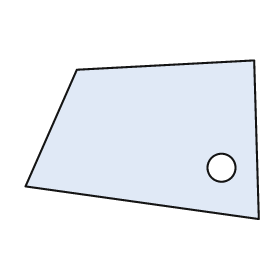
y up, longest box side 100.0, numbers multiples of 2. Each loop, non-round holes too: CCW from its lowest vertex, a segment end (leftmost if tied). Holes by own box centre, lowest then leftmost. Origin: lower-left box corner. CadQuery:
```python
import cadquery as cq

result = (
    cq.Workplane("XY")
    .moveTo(100.0, 0.0)
    .lineTo(98.0, 68.0)
    .lineTo(22.0, 64.0)
    .lineTo(0.0, 14.0)
    .close()
    .moveTo(84.0, 22.0)
    .circle(6.0)
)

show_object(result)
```